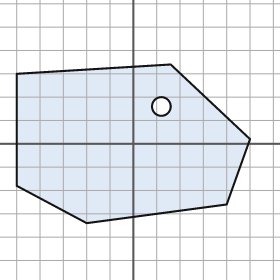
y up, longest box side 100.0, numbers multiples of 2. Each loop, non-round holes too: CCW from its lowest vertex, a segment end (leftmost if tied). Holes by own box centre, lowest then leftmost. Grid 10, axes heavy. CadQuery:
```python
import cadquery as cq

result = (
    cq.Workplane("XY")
    .moveTo(-20.0, -34.0)
    .lineTo(40.0, -26.0)
    .lineTo(50.0, 2.0)
    .lineTo(16.0, 34.0)
    .lineTo(-50.0, 30.0)
    .lineTo(-50.0, -18.0)
    .close()
    .moveTo(12.0, 16.0)
    .circle(4.0)
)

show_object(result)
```